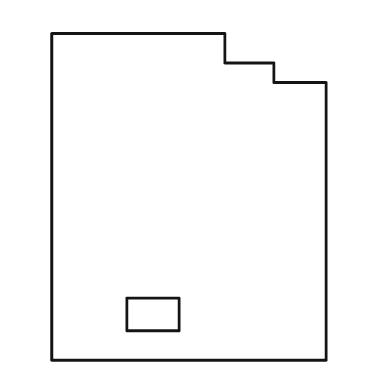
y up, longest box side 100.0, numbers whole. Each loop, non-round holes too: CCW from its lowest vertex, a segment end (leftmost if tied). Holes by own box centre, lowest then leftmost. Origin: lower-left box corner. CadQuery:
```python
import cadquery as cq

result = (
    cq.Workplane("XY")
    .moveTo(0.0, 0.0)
    .lineTo(84.0, 0.0)
    .lineTo(84.0, 85.0)
    .lineTo(68.0, 85.0)
    .lineTo(68.0, 91.0)
    .lineTo(53.0, 91.0)
    .lineTo(53.0, 100.0)
    .lineTo(0.0, 100.0)
    .close()
    .moveTo(23.0, 9.0)
    .lineTo(39.0, 9.0)
    .lineTo(39.0, 19.0)
    .lineTo(23.0, 19.0)
    .close()
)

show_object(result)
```